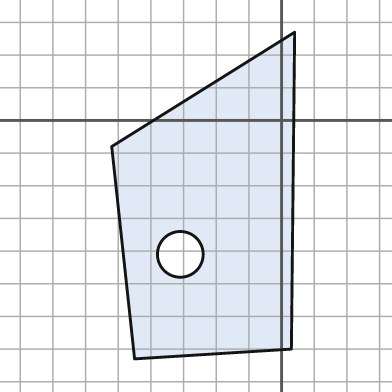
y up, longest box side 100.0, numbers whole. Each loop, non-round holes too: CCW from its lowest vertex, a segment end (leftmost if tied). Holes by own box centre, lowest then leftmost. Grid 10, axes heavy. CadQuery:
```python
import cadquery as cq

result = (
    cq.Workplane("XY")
    .moveTo(-45.0, -73.0)
    .lineTo(3.0, -70.0)
    .lineTo(4.0, 27.0)
    .lineTo(-52.0, -8.0)
    .close()
    .moveTo(-31.0, -41.0)
    .circle(7.0)
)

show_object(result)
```